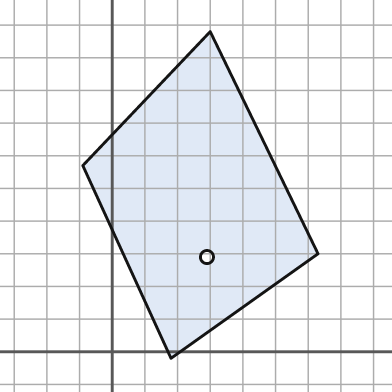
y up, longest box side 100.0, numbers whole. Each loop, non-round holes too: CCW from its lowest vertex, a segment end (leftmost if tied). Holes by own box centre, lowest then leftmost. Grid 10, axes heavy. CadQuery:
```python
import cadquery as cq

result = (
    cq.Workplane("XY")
    .moveTo(18.0, -2.0)
    .lineTo(63.0, 30.0)
    .lineTo(30.0, 98.0)
    .lineTo(-9.0, 57.0)
    .close()
    .moveTo(29.0, 29.0)
    .circle(2.0)
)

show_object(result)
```